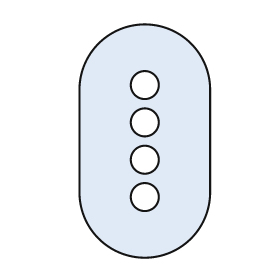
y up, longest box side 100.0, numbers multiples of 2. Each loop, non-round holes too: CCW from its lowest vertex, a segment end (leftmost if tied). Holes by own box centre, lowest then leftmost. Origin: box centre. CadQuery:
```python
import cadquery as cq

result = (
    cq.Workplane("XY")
    .moveTo(-28.0, -22.0)
    .threePointArc((0.0, -50.0), (28.0, -22.0))
    .lineTo(28.0, 22.0)
    .threePointArc((0.0, 50.0), (-28.0, 22.0))
    .close()
    .moveTo(0.0, -24.0)
    .circle(6.0)
    .moveTo(0.0, -8.0)
    .circle(6.0)
    .moveTo(0.0, 8.0)
    .circle(6.0)
    .moveTo(0.0, 24.0)
    .circle(6.0)
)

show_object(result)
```